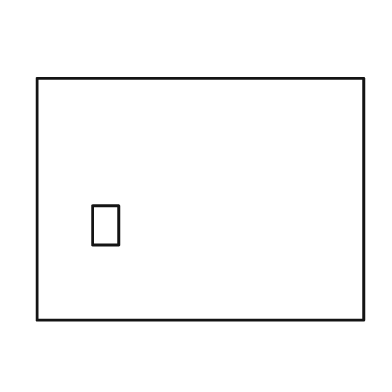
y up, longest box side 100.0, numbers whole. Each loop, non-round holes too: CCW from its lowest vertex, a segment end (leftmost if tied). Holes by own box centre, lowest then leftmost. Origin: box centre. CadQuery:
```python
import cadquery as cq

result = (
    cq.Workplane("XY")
    .moveTo(-50.0, -37.0)
    .lineTo(50.0, -37.0)
    .lineTo(50.0, 37.0)
    .lineTo(-50.0, 37.0)
    .close()
    .moveTo(-33.0, -14.0)
    .lineTo(-25.0, -14.0)
    .lineTo(-25.0, -2.0)
    .lineTo(-33.0, -2.0)
    .close()
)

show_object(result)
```